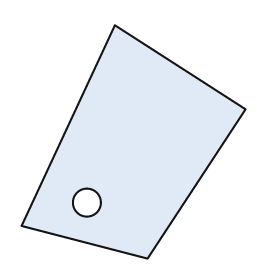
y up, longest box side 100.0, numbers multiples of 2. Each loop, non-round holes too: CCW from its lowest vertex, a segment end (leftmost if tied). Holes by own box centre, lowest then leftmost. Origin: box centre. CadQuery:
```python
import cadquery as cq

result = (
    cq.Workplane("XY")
    .moveTo(6.0, -50.0)
    .lineTo(48.0, 14.0)
    .lineTo(-8.0, 50.0)
    .lineTo(-48.0, -36.0)
    .close()
    .moveTo(-20.0, -26.0)
    .circle(6.0)
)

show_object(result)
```